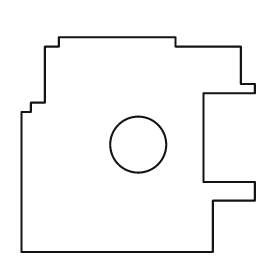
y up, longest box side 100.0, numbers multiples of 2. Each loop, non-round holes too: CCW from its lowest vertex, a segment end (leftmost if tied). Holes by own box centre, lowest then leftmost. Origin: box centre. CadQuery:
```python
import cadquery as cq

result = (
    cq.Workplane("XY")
    .moveTo(-50.0, -46.0)
    .lineTo(32.0, -46.0)
    .lineTo(32.0, -24.0)
    .lineTo(50.0, -24.0)
    .lineTo(50.0, -16.0)
    .lineTo(28.0, -16.0)
    .lineTo(28.0, 22.0)
    .lineTo(50.0, 22.0)
    .lineTo(50.0, 26.0)
    .lineTo(44.0, 26.0)
    .lineTo(44.0, 42.0)
    .lineTo(16.0, 42.0)
    .lineTo(16.0, 46.0)
    .lineTo(-34.0, 46.0)
    .lineTo(-34.0, 42.0)
    .lineTo(-40.0, 42.0)
    .lineTo(-40.0, 18.0)
    .lineTo(-46.0, 18.0)
    .lineTo(-46.0, 14.0)
    .lineTo(-50.0, 14.0)
    .close()
    .moveTo(0.0, 0.0)
    .circle(12.0)
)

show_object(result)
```